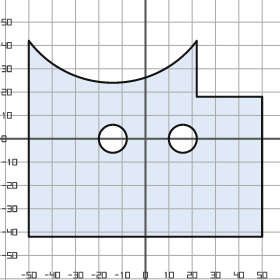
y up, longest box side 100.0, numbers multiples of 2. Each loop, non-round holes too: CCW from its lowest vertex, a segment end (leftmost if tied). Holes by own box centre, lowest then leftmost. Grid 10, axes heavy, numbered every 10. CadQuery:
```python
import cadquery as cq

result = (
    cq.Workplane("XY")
    .moveTo(-50.0, -42.0)
    .lineTo(50.0, -42.0)
    .lineTo(50.0, 18.0)
    .lineTo(22.0, 18.0)
    .lineTo(22.0, 42.0)
    .threePointArc((-14.0, 24.0), (-50.0, 42.0))
    .close()
    .moveTo(-14.0, 0.0)
    .circle(6.0)
    .moveTo(16.0, 0.0)
    .circle(6.0)
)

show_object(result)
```